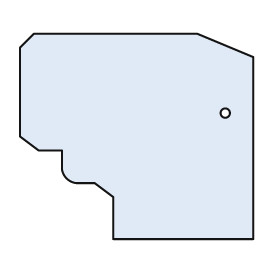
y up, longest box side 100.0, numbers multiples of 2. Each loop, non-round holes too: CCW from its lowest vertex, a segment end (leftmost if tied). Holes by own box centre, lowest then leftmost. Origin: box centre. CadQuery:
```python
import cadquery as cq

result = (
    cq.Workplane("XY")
    .moveTo(-10.0, -44.0)
    .lineTo(50.0, -44.0)
    .lineTo(50.0, 34.0)
    .lineTo(26.0, 44.0)
    .lineTo(-44.0, 44.0)
    .lineTo(-50.0, 38.0)
    .lineTo(-50.0, 0.0)
    .lineTo(-42.0, -6.0)
    .lineTo(-32.0, -6.0)
    .lineTo(-32.0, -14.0)
    .threePointArc((-30.0, -18.0), (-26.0, -20.0))
    .lineTo(-18.0, -20.0)
    .lineTo(-10.0, -26.0)
    .close()
    .moveTo(38.0, 10.0)
    .circle(2.0)
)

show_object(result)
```